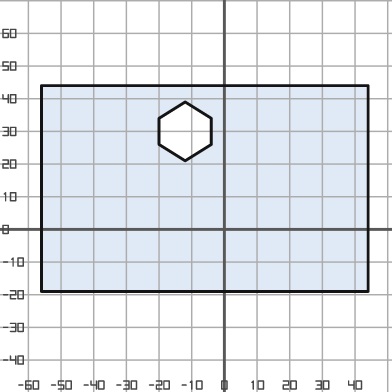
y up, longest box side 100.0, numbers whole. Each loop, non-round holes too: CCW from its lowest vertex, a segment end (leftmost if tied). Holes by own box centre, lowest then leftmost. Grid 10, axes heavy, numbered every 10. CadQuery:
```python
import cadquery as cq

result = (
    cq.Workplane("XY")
    .moveTo(-56.0, -19.0)
    .lineTo(44.0, -19.0)
    .lineTo(44.0, 44.0)
    .lineTo(-56.0, 44.0)
    .close()
    .moveTo(-12.0, 21.0)
    .lineTo(-4.0, 26.0)
    .lineTo(-4.0, 34.0)
    .lineTo(-12.0, 39.0)
    .lineTo(-20.0, 34.0)
    .lineTo(-20.0, 26.0)
    .close()
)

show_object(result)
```